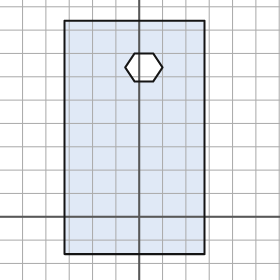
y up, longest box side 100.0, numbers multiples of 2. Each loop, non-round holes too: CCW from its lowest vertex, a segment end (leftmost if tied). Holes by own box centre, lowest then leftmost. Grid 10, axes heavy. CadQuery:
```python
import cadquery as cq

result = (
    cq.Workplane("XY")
    .moveTo(-32.0, -16.0)
    .lineTo(28.0, -16.0)
    .lineTo(28.0, 84.0)
    .lineTo(-32.0, 84.0)
    .close()
    .moveTo(-2.0, 58.0)
    .lineTo(6.0, 58.0)
    .lineTo(10.0, 64.0)
    .lineTo(6.0, 70.0)
    .lineTo(-2.0, 70.0)
    .lineTo(-6.0, 64.0)
    .close()
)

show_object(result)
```